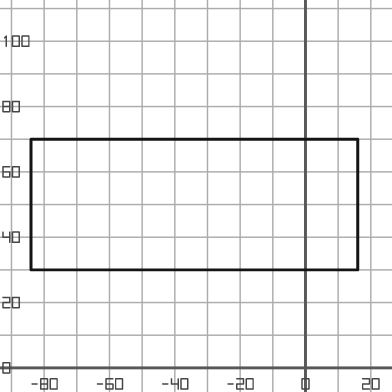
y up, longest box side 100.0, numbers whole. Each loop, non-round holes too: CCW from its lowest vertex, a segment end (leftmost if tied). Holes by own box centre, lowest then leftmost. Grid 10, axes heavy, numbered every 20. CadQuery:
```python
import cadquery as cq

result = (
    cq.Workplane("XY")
    .moveTo(-84.0, 30.0)
    .lineTo(16.0, 30.0)
    .lineTo(16.0, 70.0)
    .lineTo(-84.0, 70.0)
    .close()
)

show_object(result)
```